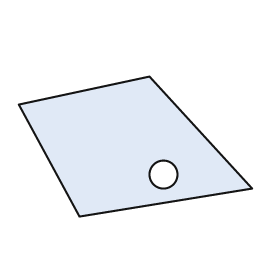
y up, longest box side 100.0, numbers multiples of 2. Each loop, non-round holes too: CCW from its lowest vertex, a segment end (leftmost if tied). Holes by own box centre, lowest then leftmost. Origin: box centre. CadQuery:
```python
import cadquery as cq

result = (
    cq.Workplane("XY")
    .moveTo(-24.0, -30.0)
    .lineTo(50.0, -18.0)
    .lineTo(6.0, 30.0)
    .lineTo(-50.0, 18.0)
    .close()
    .moveTo(12.0, -12.0)
    .circle(6.0)
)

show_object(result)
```